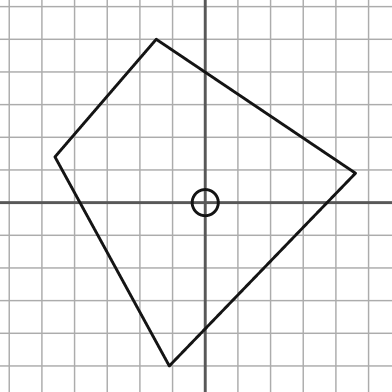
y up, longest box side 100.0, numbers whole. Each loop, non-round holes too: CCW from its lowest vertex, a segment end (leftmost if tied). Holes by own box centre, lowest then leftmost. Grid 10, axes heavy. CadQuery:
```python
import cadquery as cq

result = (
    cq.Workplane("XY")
    .moveTo(-11.0, -50.0)
    .lineTo(46.0, 9.0)
    .lineTo(-15.0, 50.0)
    .lineTo(-46.0, 14.0)
    .close()
    .moveTo(0.0, 0.0)
    .circle(4.0)
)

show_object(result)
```